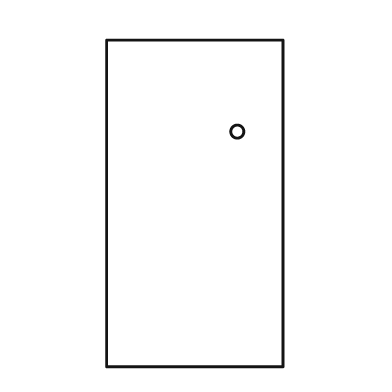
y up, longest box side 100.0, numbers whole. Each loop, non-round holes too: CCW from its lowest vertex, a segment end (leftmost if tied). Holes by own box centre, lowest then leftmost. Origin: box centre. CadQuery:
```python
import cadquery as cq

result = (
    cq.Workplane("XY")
    .moveTo(-27.0, -50.0)
    .lineTo(27.0, -50.0)
    .lineTo(27.0, 50.0)
    .lineTo(-27.0, 50.0)
    .close()
    .moveTo(13.0, 22.0)
    .circle(2.0)
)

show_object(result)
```